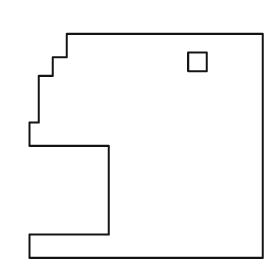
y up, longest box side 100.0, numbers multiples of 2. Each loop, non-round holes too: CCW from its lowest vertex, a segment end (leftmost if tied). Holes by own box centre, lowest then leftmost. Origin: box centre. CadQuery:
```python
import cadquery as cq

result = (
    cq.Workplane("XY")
    .moveTo(-50.0, -48.0)
    .lineTo(50.0, -48.0)
    .lineTo(50.0, 48.0)
    .lineTo(-34.0, 48.0)
    .lineTo(-34.0, 38.0)
    .lineTo(-40.0, 38.0)
    .lineTo(-40.0, 30.0)
    .lineTo(-46.0, 30.0)
    .lineTo(-46.0, 10.0)
    .lineTo(-50.0, 10.0)
    .lineTo(-50.0, 0.0)
    .lineTo(-16.0, 0.0)
    .lineTo(-16.0, -38.0)
    .lineTo(-50.0, -38.0)
    .close()
    .moveTo(18.0, 32.0)
    .lineTo(26.0, 32.0)
    .lineTo(26.0, 40.0)
    .lineTo(18.0, 40.0)
    .close()
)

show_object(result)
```